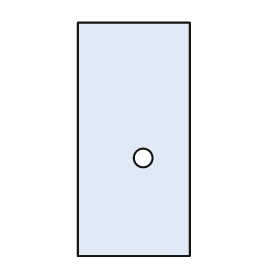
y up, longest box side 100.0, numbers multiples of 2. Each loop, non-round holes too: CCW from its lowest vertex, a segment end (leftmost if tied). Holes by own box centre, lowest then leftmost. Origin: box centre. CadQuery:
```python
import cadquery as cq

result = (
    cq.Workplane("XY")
    .moveTo(-24.0, -50.0)
    .lineTo(24.0, -50.0)
    .lineTo(24.0, 50.0)
    .lineTo(-24.0, 50.0)
    .close()
    .moveTo(4.0, -8.0)
    .circle(4.0)
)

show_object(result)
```